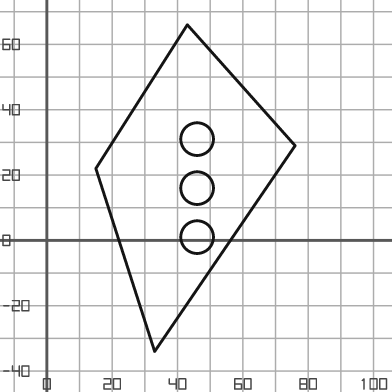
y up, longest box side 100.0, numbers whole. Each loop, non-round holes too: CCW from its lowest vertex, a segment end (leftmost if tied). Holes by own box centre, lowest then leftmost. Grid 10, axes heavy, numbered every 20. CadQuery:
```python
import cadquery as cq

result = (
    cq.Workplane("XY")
    .moveTo(33.0, -34.0)
    .lineTo(76.0, 29.0)
    .lineTo(43.0, 66.0)
    .lineTo(15.0, 22.0)
    .close()
    .moveTo(46.0, 1.0)
    .circle(5.0)
    .moveTo(46.0, 16.0)
    .circle(5.0)
    .moveTo(46.0, 31.0)
    .circle(5.0)
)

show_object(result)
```